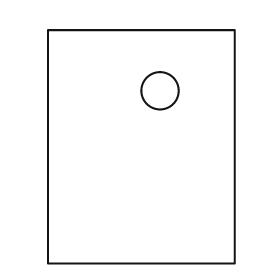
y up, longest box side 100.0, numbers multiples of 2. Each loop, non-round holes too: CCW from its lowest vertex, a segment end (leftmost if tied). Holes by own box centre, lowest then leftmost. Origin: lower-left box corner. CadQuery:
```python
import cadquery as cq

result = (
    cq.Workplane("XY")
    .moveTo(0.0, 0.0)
    .lineTo(80.0, 0.0)
    .lineTo(80.0, 100.0)
    .lineTo(0.0, 100.0)
    .close()
    .moveTo(48.0, 74.0)
    .circle(8.0)
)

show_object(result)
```